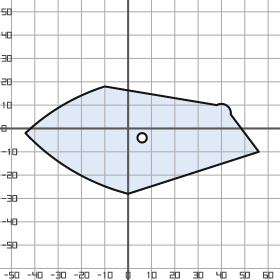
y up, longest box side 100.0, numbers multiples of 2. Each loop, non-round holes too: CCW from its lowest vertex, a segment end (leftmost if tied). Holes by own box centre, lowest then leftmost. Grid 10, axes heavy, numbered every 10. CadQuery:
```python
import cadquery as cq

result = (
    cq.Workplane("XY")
    .moveTo(0.0, -28.0)
    .lineTo(56.0, -10.0)
    .lineTo(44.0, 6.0)
    .threePointArc((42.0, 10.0), (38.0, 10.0))
    .lineTo(-10.0, 18.0)
    .threePointArc((-28.0, 10.0), (-44.0, -2.0))
    .threePointArc((-24.0, -18.0), (0.0, -28.0))
    .close()
    .moveTo(6.0, -4.0)
    .circle(2.0)
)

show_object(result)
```